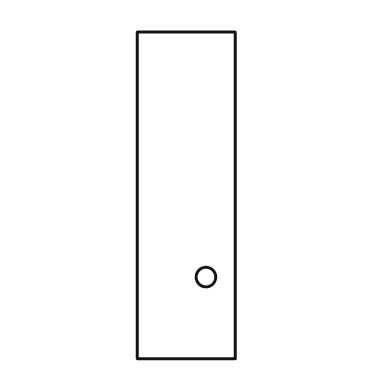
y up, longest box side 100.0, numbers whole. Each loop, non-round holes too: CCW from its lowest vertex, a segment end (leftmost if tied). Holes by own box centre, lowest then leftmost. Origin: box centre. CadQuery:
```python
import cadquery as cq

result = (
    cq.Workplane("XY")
    .moveTo(-15.0, -50.0)
    .lineTo(15.0, -50.0)
    .lineTo(15.0, 50.0)
    .lineTo(-15.0, 50.0)
    .close()
    .moveTo(6.0, -25.0)
    .circle(3.0)
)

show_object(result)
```